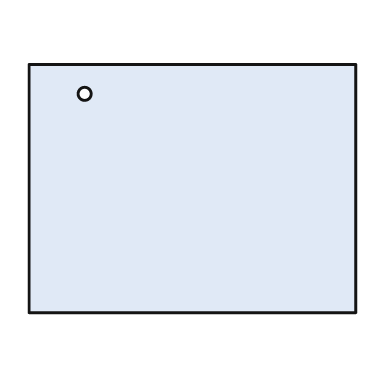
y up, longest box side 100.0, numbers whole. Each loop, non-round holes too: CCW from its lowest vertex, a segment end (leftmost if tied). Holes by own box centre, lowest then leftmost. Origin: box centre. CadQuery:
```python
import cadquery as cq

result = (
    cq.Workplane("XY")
    .moveTo(-50.0, -38.0)
    .lineTo(50.0, -38.0)
    .lineTo(50.0, 38.0)
    .lineTo(-50.0, 38.0)
    .close()
    .moveTo(-33.0, 29.0)
    .circle(2.0)
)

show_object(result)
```